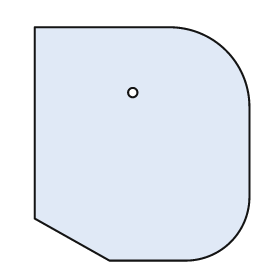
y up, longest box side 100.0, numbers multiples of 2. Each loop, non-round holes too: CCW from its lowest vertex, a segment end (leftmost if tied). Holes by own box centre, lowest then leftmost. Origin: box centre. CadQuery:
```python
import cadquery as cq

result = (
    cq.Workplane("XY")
    .moveTo(-14.0, -50.0)
    .lineTo(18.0, -50.0)
    .threePointArc((38.0, -42.0), (46.0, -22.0))
    .lineTo(46.0, 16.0)
    .threePointArc((36.0, 40.0), (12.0, 50.0))
    .lineTo(-46.0, 50.0)
    .lineTo(-46.0, -32.0)
    .close()
    .moveTo(-4.0, 22.0)
    .circle(2.0)
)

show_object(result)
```